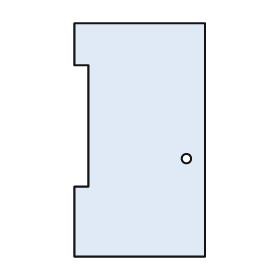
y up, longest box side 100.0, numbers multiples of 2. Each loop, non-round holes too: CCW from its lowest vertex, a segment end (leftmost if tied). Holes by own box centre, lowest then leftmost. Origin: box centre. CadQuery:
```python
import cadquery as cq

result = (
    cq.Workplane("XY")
    .moveTo(-28.0, -50.0)
    .lineTo(28.0, -50.0)
    .lineTo(28.0, 50.0)
    .lineTo(-28.0, 50.0)
    .lineTo(-28.0, 32.0)
    .lineTo(-22.0, 32.0)
    .lineTo(-22.0, -20.0)
    .lineTo(-28.0, -20.0)
    .close()
    .moveTo(20.0, -8.0)
    .circle(2.0)
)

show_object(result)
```